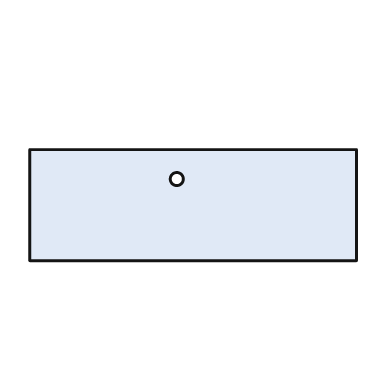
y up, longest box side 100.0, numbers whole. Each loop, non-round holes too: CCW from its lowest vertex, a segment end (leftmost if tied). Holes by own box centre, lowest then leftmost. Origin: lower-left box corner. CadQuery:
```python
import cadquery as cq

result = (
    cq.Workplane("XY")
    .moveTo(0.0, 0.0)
    .lineTo(100.0, 0.0)
    .lineTo(100.0, 34.0)
    .lineTo(0.0, 34.0)
    .close()
    .moveTo(45.0, 25.0)
    .circle(2.0)
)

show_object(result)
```